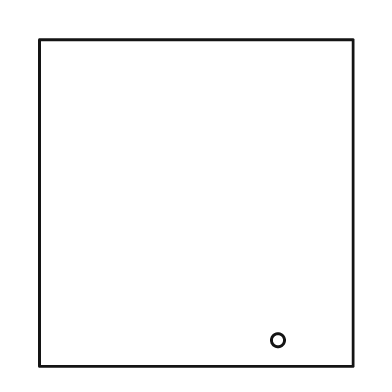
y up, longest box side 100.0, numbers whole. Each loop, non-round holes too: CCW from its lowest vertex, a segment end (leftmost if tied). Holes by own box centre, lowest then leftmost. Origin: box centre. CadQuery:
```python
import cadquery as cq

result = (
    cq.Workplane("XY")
    .moveTo(-48.0, -50.0)
    .lineTo(48.0, -50.0)
    .lineTo(48.0, 50.0)
    .lineTo(-48.0, 50.0)
    .close()
    .moveTo(25.0, -42.0)
    .circle(2.0)
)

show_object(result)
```